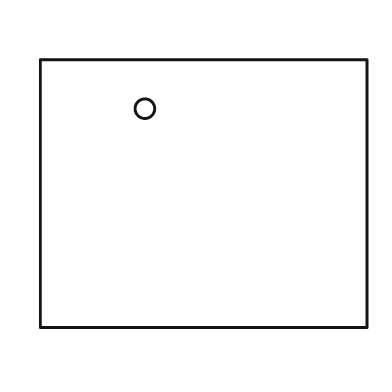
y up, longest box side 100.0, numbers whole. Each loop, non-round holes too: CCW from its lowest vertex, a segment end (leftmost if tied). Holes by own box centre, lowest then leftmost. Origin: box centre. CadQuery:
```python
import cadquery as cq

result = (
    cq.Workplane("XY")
    .moveTo(-50.0, -41.0)
    .lineTo(50.0, -41.0)
    .lineTo(50.0, 41.0)
    .lineTo(-50.0, 41.0)
    .close()
    .moveTo(-18.0, 26.0)
    .circle(3.0)
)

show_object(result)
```